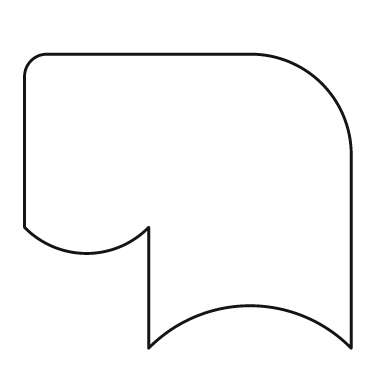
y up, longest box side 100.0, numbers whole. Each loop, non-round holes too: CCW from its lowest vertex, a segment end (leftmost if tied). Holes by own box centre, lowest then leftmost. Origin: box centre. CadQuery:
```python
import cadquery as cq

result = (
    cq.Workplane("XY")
    .moveTo(-12.0, -45.0)
    .threePointArc((19.0, -32.0), (50.0, -45.0))
    .lineTo(50.0, 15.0)
    .threePointArc((41.0, 36.0), (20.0, 45.0))
    .lineTo(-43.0, 45.0)
    .threePointArc((-48.0, 43.0), (-50.0, 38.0))
    .lineTo(-50.0, -8.0)
    .threePointArc((-31.0, -16.0), (-12.0, -8.0))
    .close()
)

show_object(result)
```